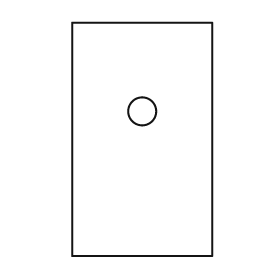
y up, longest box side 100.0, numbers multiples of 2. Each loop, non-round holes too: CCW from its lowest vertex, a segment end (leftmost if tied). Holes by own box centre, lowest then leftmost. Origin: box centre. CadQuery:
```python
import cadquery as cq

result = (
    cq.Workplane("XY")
    .moveTo(-30.0, -50.0)
    .lineTo(30.0, -50.0)
    .lineTo(30.0, 50.0)
    .lineTo(-30.0, 50.0)
    .close()
    .moveTo(0.0, 12.0)
    .circle(6.0)
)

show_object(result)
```